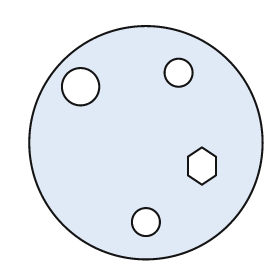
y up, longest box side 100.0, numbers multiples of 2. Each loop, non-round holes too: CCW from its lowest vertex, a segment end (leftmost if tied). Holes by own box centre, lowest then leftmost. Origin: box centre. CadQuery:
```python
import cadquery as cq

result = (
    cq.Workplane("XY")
    .moveTo(0.0, 0.0)
    .circle(50.0)
    .moveTo(0.0, -34.0)
    .circle(6.0)
    .moveTo(24.0, -18.0)
    .lineTo(30.0, -14.0)
    .lineTo(30.0, -6.0)
    .lineTo(24.0, -2.0)
    .lineTo(18.0, -6.0)
    .lineTo(18.0, -14.0)
    .close()
    .moveTo(-28.0, 24.0)
    .circle(8.0)
    .moveTo(14.0, 30.0)
    .circle(6.0)
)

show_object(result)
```